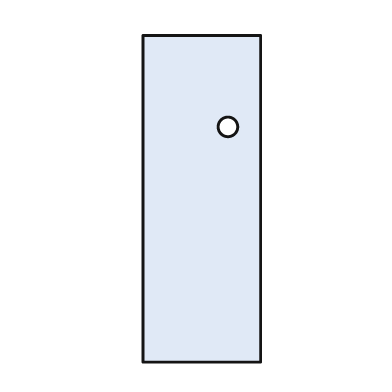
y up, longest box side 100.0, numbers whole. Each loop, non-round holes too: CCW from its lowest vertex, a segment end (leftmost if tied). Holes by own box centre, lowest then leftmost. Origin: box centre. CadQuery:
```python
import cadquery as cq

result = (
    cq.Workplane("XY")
    .moveTo(-18.0, -50.0)
    .lineTo(18.0, -50.0)
    .lineTo(18.0, 50.0)
    .lineTo(-18.0, 50.0)
    .close()
    .moveTo(8.0, 22.0)
    .circle(3.0)
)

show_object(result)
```